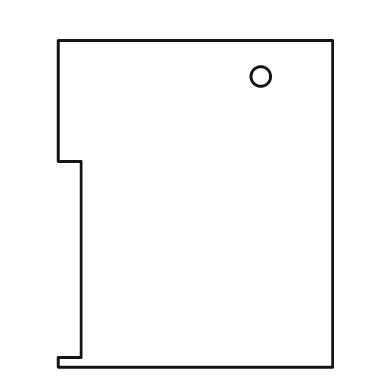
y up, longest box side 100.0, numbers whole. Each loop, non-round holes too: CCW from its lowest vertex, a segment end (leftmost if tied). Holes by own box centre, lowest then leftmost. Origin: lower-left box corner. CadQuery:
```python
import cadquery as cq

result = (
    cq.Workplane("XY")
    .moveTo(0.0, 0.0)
    .lineTo(84.0, 0.0)
    .lineTo(84.0, 100.0)
    .lineTo(0.0, 100.0)
    .lineTo(0.0, 63.0)
    .lineTo(7.0, 63.0)
    .lineTo(7.0, 3.0)
    .lineTo(0.0, 3.0)
    .close()
    .moveTo(62.0, 89.0)
    .circle(3.0)
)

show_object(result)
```